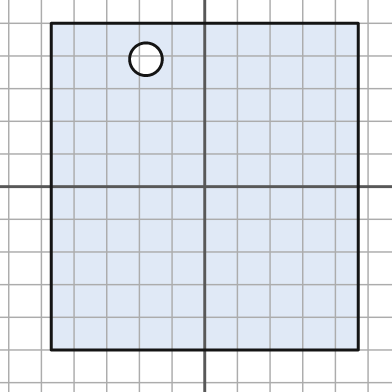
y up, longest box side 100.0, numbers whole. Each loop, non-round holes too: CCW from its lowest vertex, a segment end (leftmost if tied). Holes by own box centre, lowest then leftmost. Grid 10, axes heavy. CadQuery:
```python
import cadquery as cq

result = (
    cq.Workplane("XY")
    .moveTo(-47.0, -50.0)
    .lineTo(47.0, -50.0)
    .lineTo(47.0, 50.0)
    .lineTo(-47.0, 50.0)
    .close()
    .moveTo(-18.0, 39.0)
    .circle(5.0)
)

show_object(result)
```